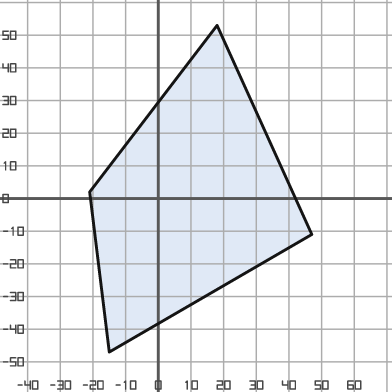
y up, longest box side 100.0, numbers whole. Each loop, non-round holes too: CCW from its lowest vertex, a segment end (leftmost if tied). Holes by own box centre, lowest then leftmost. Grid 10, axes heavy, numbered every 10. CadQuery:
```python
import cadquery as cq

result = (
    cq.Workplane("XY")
    .moveTo(-15.0, -47.0)
    .lineTo(47.0, -11.0)
    .lineTo(18.0, 53.0)
    .lineTo(-21.0, 2.0)
    .close()
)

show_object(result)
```